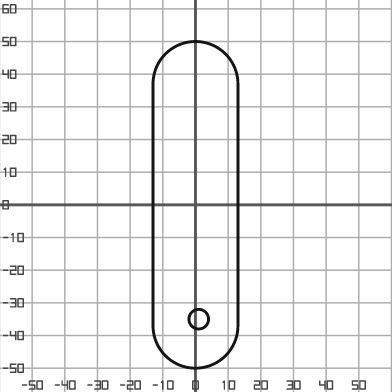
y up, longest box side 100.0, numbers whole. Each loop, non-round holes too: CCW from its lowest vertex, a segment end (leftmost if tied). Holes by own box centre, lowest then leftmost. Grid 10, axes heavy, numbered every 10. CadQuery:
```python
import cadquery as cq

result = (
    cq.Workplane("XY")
    .moveTo(-13.0, -37.0)
    .threePointArc((0.0, -50.0), (13.0, -37.0))
    .lineTo(13.0, 37.0)
    .threePointArc((0.0, 50.0), (-13.0, 37.0))
    .close()
    .moveTo(1.0, -35.0)
    .circle(3.0)
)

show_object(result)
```